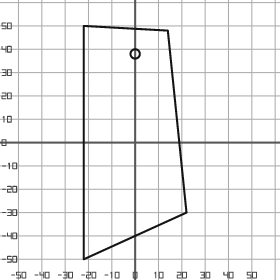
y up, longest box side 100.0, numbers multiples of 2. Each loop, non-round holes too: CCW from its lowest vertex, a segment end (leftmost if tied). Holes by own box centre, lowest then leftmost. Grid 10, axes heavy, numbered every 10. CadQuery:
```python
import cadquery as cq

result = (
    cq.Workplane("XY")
    .moveTo(-22.0, -50.0)
    .lineTo(22.0, -30.0)
    .lineTo(14.0, 48.0)
    .lineTo(-22.0, 50.0)
    .close()
    .moveTo(0.0, 38.0)
    .circle(2.0)
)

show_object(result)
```